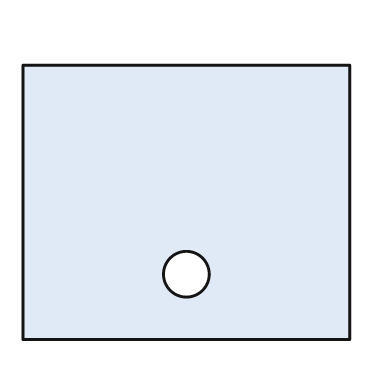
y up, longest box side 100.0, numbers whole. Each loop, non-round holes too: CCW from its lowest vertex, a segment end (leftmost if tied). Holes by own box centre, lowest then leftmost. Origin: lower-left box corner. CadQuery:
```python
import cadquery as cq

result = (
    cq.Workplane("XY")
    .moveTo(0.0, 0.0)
    .lineTo(100.0, 0.0)
    .lineTo(100.0, 84.0)
    .lineTo(0.0, 84.0)
    .close()
    .moveTo(50.0, 20.0)
    .circle(7.0)
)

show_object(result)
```